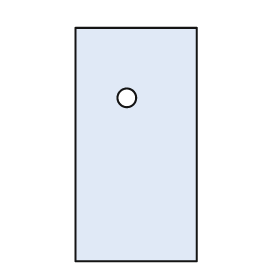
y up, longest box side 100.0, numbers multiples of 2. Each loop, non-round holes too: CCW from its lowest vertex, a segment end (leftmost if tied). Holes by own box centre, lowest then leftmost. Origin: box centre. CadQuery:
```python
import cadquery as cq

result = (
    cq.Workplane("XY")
    .moveTo(-26.0, -50.0)
    .lineTo(26.0, -50.0)
    .lineTo(26.0, 50.0)
    .lineTo(-26.0, 50.0)
    .close()
    .moveTo(-4.0, 20.0)
    .circle(4.0)
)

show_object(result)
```